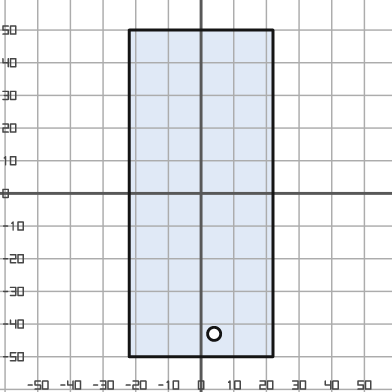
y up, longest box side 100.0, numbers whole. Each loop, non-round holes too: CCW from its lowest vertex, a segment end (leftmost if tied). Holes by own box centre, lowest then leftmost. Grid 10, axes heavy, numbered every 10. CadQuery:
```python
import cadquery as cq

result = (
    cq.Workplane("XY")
    .moveTo(-22.0, -50.0)
    .lineTo(22.0, -50.0)
    .lineTo(22.0, 50.0)
    .lineTo(-22.0, 50.0)
    .close()
    .moveTo(4.0, -43.0)
    .circle(2.0)
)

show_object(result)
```